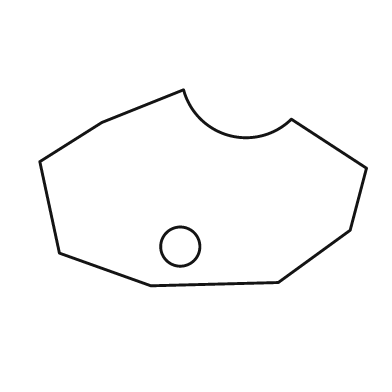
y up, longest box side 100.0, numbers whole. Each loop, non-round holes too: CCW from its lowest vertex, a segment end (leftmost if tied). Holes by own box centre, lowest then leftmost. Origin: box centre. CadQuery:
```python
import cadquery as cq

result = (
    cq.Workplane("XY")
    .moveTo(-16.0, -30.0)
    .lineTo(23.0, -29.0)
    .lineTo(45.0, -13.0)
    .lineTo(50.0, 6.0)
    .lineTo(27.0, 21.0)
    .threePointArc((8.0, 16.0), (-6.0, 30.0))
    .lineTo(-31.0, 20.0)
    .lineTo(-50.0, 8.0)
    .lineTo(-44.0, -20.0)
    .close()
    .moveTo(-7.0, -18.0)
    .circle(6.0)
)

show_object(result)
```